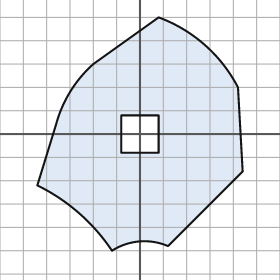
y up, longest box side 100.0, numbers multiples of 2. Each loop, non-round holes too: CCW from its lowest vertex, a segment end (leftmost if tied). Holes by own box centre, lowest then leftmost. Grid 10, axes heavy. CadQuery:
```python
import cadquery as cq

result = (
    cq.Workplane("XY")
    .moveTo(-12.0, -50.0)
    .threePointArc((0.0, -46.0), (12.0, -48.0))
    .lineTo(44.0, -16.0)
    .lineTo(42.0, 20.0)
    .threePointArc((28.0, 38.0), (8.0, 50.0))
    .lineTo(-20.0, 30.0)
    .threePointArc((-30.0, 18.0), (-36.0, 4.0))
    .lineTo(-44.0, -22.0)
    .threePointArc((-26.0, -34.0), (-12.0, -50.0))
    .close()
    .moveTo(-8.0, -8.0)
    .lineTo(8.0, -8.0)
    .lineTo(8.0, 8.0)
    .lineTo(-8.0, 8.0)
    .close()
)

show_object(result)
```